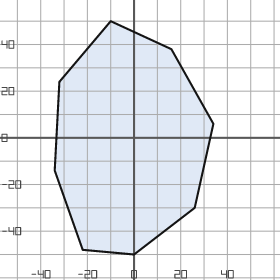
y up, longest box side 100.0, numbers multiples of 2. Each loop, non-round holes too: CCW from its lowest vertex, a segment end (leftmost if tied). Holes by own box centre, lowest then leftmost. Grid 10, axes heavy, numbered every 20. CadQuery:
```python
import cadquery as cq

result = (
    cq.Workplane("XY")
    .moveTo(0.0, -50.0)
    .lineTo(26.0, -30.0)
    .lineTo(34.0, 6.0)
    .lineTo(16.0, 38.0)
    .lineTo(-10.0, 50.0)
    .lineTo(-32.0, 24.0)
    .lineTo(-34.0, -14.0)
    .lineTo(-22.0, -48.0)
    .close()
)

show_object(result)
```